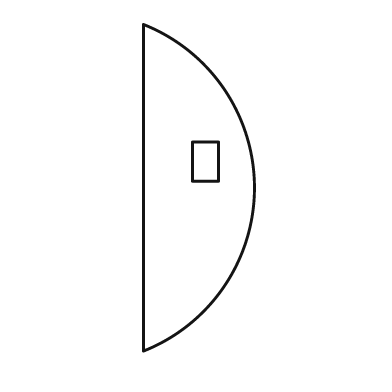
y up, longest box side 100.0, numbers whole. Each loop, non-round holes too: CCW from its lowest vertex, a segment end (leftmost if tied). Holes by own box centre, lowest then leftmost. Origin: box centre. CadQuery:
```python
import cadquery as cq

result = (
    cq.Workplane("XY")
    .moveTo(-17.0, -50.0)
    .threePointArc((17.0, 0.0), (-17.0, 50.0))
    .close()
    .moveTo(-2.0, 2.0)
    .lineTo(6.0, 2.0)
    .lineTo(6.0, 14.0)
    .lineTo(-2.0, 14.0)
    .close()
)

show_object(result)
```